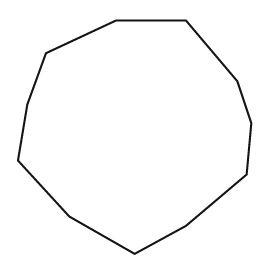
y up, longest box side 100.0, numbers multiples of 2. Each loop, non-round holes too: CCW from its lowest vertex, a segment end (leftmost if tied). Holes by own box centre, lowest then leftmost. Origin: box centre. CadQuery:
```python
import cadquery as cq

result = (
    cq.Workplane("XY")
    .moveTo(0.0, -50.0)
    .lineTo(22.0, -38.0)
    .lineTo(48.0, -16.0)
    .lineTo(50.0, 6.0)
    .lineTo(44.0, 24.0)
    .lineTo(22.0, 50.0)
    .lineTo(-8.0, 50.0)
    .lineTo(-38.0, 36.0)
    .lineTo(-46.0, 14.0)
    .lineTo(-50.0, -10.0)
    .lineTo(-28.0, -34.0)
    .close()
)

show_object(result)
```